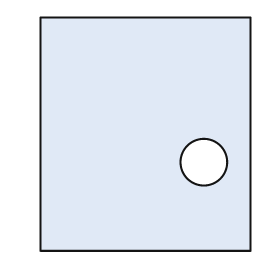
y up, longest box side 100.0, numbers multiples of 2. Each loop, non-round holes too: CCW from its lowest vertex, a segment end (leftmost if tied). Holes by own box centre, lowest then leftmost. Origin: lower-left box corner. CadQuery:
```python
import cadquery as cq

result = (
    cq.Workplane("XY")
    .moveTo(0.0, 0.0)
    .lineTo(90.0, 0.0)
    .lineTo(90.0, 100.0)
    .lineTo(0.0, 100.0)
    .close()
    .moveTo(70.0, 38.0)
    .circle(10.0)
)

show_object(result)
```